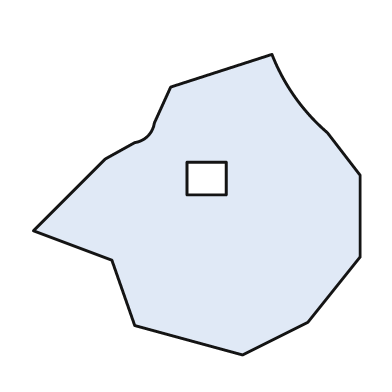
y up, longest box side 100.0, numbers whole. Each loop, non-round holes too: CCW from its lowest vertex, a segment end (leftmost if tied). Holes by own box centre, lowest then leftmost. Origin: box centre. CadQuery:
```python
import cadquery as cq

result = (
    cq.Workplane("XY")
    .moveTo(14.0, -46.0)
    .lineTo(34.0, -36.0)
    .lineTo(50.0, -16.0)
    .lineTo(50.0, 9.0)
    .lineTo(40.0, 22.0)
    .threePointArc((30.0, 33.0), (23.0, 46.0))
    .lineTo(-8.0, 36.0)
    .lineTo(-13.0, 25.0)
    .threePointArc((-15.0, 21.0), (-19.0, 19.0))
    .lineTo(-28.0, 14.0)
    .lineTo(-50.0, -8.0)
    .lineTo(-26.0, -17.0)
    .lineTo(-19.0, -37.0)
    .close()
    .moveTo(-3.0, 3.0)
    .lineTo(9.0, 3.0)
    .lineTo(9.0, 13.0)
    .lineTo(-3.0, 13.0)
    .close()
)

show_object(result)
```